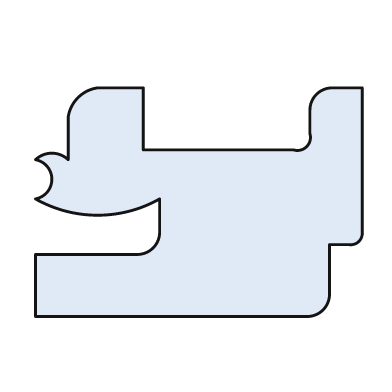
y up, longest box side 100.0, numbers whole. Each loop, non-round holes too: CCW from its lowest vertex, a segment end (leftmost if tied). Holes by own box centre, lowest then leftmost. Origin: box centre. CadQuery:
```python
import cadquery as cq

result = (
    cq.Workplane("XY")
    .moveTo(-50.0, -35.0)
    .lineTo(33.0, -35.0)
    .threePointArc((38.0, -33.0), (40.0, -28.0))
    .lineTo(40.0, -13.0)
    .lineTo(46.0, -13.0)
    .threePointArc((49.0, -12.0), (50.0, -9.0))
    .lineTo(50.0, 35.0)
    .lineTo(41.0, 35.0)
    .threePointArc((36.0, 33.0), (34.0, 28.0))
    .lineTo(34.0, 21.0)
    .threePointArc((33.0, 17.0), (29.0, 16.0))
    .lineTo(-17.0, 16.0)
    .lineTo(-17.0, 35.0)
    .lineTo(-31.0, 35.0)
    .threePointArc((-37.0, 32.0), (-40.0, 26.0))
    .lineTo(-40.0, 13.0)
    .threePointArc((-45.0, 15.0), (-50.0, 13.0))
    .threePointArc((-45.0, 7.0), (-50.0, 1.0))
    .threePointArc((-31.0, -4.0), (-12.0, 1.0))
    .lineTo(-12.0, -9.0)
    .threePointArc((-14.0, -14.0), (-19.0, -16.0))
    .lineTo(-50.0, -16.0)
    .close()
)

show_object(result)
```